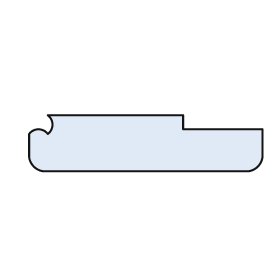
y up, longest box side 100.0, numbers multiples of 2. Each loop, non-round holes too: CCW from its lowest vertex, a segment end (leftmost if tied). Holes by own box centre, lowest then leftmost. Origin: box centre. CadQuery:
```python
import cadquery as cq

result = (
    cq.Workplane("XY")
    .moveTo(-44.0, -12.0)
    .lineTo(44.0, -12.0)
    .threePointArc((48.0, -10.0), (50.0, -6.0))
    .lineTo(50.0, 6.0)
    .lineTo(16.0, 6.0)
    .lineTo(16.0, 12.0)
    .lineTo(-42.0, 12.0)
    .threePointArc((-40.0, 8.0), (-42.0, 4.0))
    .threePointArc((-46.0, 6.0), (-50.0, 4.0))
    .lineTo(-50.0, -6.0)
    .threePointArc((-48.0, -10.0), (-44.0, -12.0))
    .close()
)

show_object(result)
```